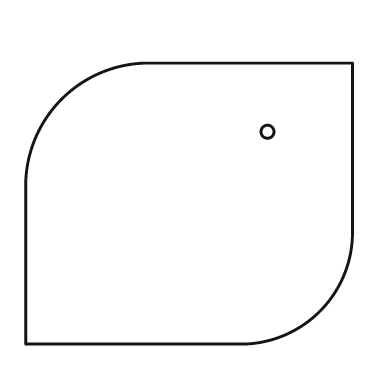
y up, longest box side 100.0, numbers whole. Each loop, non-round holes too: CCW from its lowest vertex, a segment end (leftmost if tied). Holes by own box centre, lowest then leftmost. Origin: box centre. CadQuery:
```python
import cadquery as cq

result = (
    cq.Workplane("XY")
    .moveTo(-50.0, -43.0)
    .lineTo(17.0, -43.0)
    .threePointArc((40.0, -33.0), (50.0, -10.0))
    .lineTo(50.0, 43.0)
    .lineTo(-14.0, 43.0)
    .threePointArc((-39.0, 32.0), (-50.0, 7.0))
    .close()
    .moveTo(24.0, 22.0)
    .circle(2.0)
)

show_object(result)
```